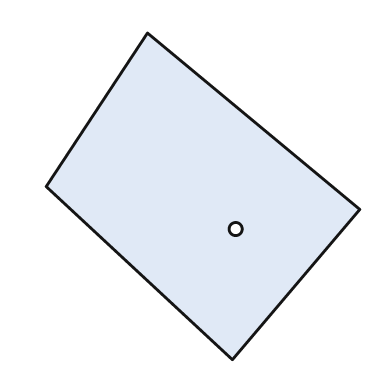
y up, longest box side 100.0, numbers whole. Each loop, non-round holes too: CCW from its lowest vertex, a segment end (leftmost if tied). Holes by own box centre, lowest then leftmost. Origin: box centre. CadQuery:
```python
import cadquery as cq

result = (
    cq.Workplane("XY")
    .moveTo(9.0, -50.0)
    .lineTo(48.0, -4.0)
    .lineTo(-17.0, 50.0)
    .lineTo(-48.0, 3.0)
    .close()
    .moveTo(10.0, -10.0)
    .circle(2.0)
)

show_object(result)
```